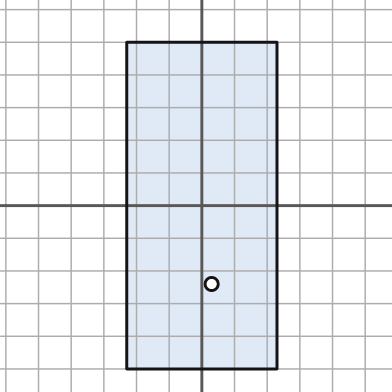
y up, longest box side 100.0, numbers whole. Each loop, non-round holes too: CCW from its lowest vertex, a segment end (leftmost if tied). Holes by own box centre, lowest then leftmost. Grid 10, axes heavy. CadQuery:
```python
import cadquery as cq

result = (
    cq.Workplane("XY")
    .moveTo(-23.0, -50.0)
    .lineTo(23.0, -50.0)
    .lineTo(23.0, 50.0)
    .lineTo(-23.0, 50.0)
    .close()
    .moveTo(3.0, -24.0)
    .circle(2.0)
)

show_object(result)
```